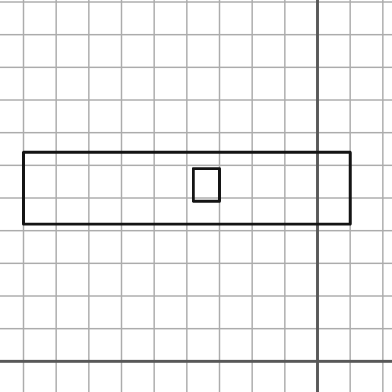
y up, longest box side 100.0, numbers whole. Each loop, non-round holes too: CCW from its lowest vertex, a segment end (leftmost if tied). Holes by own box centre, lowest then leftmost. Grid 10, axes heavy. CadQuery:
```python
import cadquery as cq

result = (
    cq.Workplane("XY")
    .moveTo(-90.0, 42.0)
    .lineTo(10.0, 42.0)
    .lineTo(10.0, 64.0)
    .lineTo(-90.0, 64.0)
    .close()
    .moveTo(-38.0, 49.0)
    .lineTo(-30.0, 49.0)
    .lineTo(-30.0, 59.0)
    .lineTo(-38.0, 59.0)
    .close()
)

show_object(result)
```